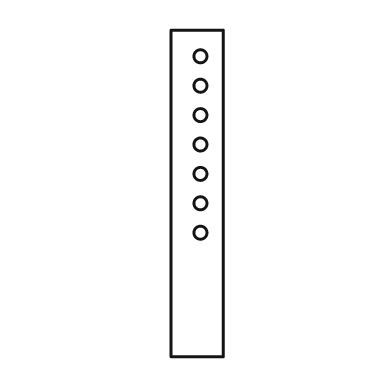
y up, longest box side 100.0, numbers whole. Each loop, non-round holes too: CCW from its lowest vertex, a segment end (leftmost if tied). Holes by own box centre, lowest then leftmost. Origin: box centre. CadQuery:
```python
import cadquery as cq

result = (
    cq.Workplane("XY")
    .moveTo(-8.0, -50.0)
    .lineTo(8.0, -50.0)
    .lineTo(8.0, 50.0)
    .lineTo(-8.0, 50.0)
    .close()
    .moveTo(1.0, -12.0)
    .circle(2.0)
    .moveTo(1.0, -3.0)
    .circle(2.0)
    .moveTo(1.0, 6.0)
    .circle(2.0)
    .moveTo(1.0, 15.0)
    .circle(2.0)
    .moveTo(1.0, 24.0)
    .circle(2.0)
    .moveTo(1.0, 33.0)
    .circle(2.0)
    .moveTo(1.0, 42.0)
    .circle(2.0)
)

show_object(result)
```